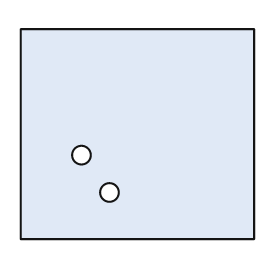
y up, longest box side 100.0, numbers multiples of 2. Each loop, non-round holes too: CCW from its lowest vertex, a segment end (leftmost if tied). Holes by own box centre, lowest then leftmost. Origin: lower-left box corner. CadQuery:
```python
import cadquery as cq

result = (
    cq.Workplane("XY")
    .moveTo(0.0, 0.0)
    .lineTo(100.0, 0.0)
    .lineTo(100.0, 90.0)
    .lineTo(0.0, 90.0)
    .close()
    .moveTo(38.0, 20.0)
    .circle(4.0)
    .moveTo(26.0, 36.0)
    .circle(4.0)
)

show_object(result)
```